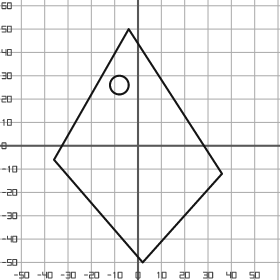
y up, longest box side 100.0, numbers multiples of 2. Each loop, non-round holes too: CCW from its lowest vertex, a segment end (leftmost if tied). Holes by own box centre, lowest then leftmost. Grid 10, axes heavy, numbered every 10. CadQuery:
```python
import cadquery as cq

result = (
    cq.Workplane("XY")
    .moveTo(2.0, -50.0)
    .lineTo(36.0, -12.0)
    .lineTo(-4.0, 50.0)
    .lineTo(-36.0, -6.0)
    .close()
    .moveTo(-8.0, 26.0)
    .circle(4.0)
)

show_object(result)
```